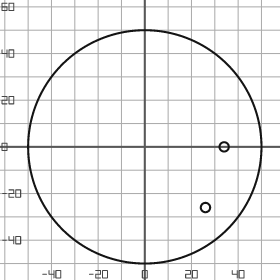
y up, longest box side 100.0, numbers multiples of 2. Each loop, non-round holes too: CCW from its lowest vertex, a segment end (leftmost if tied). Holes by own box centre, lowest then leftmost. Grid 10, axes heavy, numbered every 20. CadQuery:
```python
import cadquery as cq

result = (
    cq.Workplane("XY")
    .moveTo(0.0, 0.0)
    .circle(50.0)
    .moveTo(26.0, -26.0)
    .circle(2.0)
    .moveTo(34.0, 0.0)
    .circle(2.0)
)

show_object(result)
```